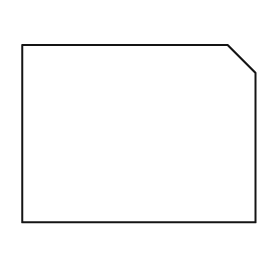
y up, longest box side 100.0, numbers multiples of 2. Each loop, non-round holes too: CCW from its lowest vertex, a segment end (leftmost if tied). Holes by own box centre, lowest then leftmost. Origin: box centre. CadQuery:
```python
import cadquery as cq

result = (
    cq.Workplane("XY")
    .moveTo(-50.0, -38.0)
    .lineTo(50.0, -38.0)
    .lineTo(50.0, 26.0)
    .lineTo(38.0, 38.0)
    .lineTo(-50.0, 38.0)
    .close()
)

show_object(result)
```